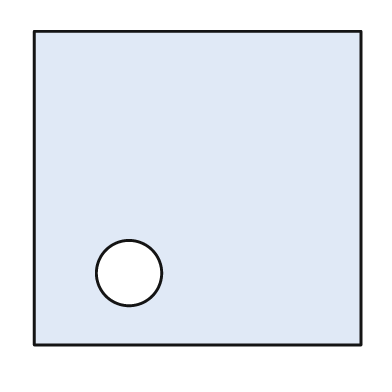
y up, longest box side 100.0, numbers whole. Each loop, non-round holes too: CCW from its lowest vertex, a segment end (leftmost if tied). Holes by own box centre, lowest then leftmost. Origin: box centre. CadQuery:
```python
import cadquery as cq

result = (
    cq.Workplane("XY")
    .moveTo(-50.0, -48.0)
    .lineTo(50.0, -48.0)
    .lineTo(50.0, 48.0)
    .lineTo(-50.0, 48.0)
    .close()
    .moveTo(-21.0, -26.0)
    .circle(10.0)
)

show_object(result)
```